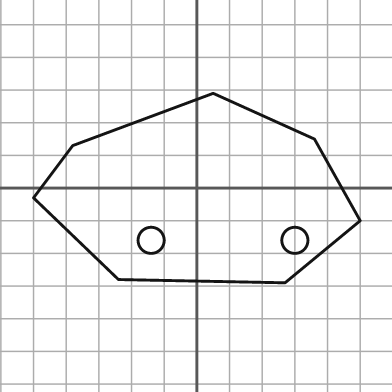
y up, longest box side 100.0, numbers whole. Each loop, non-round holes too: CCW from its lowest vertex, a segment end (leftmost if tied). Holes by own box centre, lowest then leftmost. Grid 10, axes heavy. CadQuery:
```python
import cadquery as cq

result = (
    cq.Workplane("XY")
    .moveTo(27.0, -29.0)
    .lineTo(50.0, -10.0)
    .lineTo(36.0, 15.0)
    .lineTo(5.0, 29.0)
    .lineTo(-38.0, 13.0)
    .lineTo(-50.0, -3.0)
    .lineTo(-24.0, -28.0)
    .close()
    .moveTo(-14.0, -16.0)
    .circle(4.0)
    .moveTo(30.0, -16.0)
    .circle(4.0)
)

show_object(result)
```